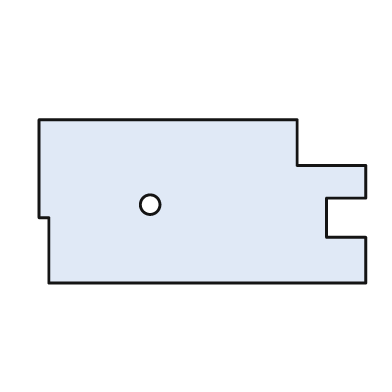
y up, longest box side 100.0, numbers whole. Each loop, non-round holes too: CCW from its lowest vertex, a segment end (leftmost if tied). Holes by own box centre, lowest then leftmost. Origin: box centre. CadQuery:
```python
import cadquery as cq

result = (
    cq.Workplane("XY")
    .moveTo(-47.0, -25.0)
    .lineTo(50.0, -25.0)
    .lineTo(50.0, -11.0)
    .lineTo(38.0, -11.0)
    .lineTo(38.0, 1.0)
    .lineTo(50.0, 1.0)
    .lineTo(50.0, 11.0)
    .lineTo(29.0, 11.0)
    .lineTo(29.0, 25.0)
    .lineTo(-50.0, 25.0)
    .lineTo(-50.0, -5.0)
    .lineTo(-47.0, -5.0)
    .close()
    .moveTo(-16.0, -1.0)
    .circle(3.0)
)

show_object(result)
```